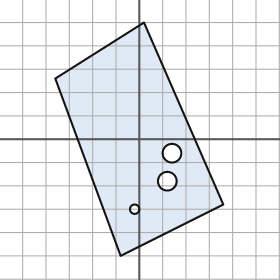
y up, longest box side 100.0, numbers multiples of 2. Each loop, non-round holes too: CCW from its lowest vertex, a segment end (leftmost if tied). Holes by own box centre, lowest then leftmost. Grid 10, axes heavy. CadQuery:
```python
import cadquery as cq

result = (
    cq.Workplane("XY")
    .moveTo(-8.0, -50.0)
    .lineTo(36.0, -28.0)
    .lineTo(2.0, 50.0)
    .lineTo(-36.0, 26.0)
    .close()
    .moveTo(-2.0, -30.0)
    .circle(2.0)
    .moveTo(12.0, -18.0)
    .circle(4.0)
    .moveTo(14.0, -6.0)
    .circle(4.0)
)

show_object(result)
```